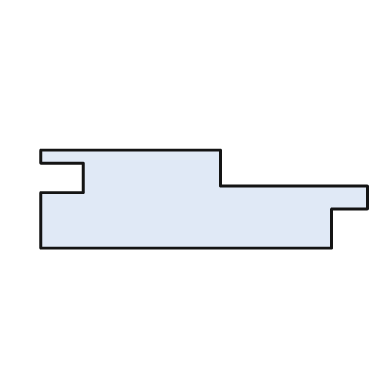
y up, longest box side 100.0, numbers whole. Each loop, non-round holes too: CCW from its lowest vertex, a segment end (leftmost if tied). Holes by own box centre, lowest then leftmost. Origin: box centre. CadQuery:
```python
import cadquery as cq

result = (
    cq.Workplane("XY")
    .moveTo(-50.0, -15.0)
    .lineTo(39.0, -15.0)
    .lineTo(39.0, -3.0)
    .lineTo(50.0, -3.0)
    .lineTo(50.0, 4.0)
    .lineTo(5.0, 4.0)
    .lineTo(5.0, 15.0)
    .lineTo(-50.0, 15.0)
    .lineTo(-50.0, 11.0)
    .lineTo(-37.0, 11.0)
    .lineTo(-37.0, 2.0)
    .lineTo(-50.0, 2.0)
    .close()
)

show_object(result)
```